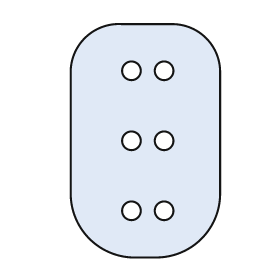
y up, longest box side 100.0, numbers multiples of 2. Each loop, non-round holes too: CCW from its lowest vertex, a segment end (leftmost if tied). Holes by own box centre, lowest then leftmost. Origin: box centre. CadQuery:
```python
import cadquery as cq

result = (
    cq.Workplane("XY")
    .moveTo(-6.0, -50.0)
    .lineTo(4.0, -50.0)
    .threePointArc((24.0, -42.0), (32.0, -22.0))
    .lineTo(32.0, 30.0)
    .threePointArc((26.0, 44.0), (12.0, 50.0))
    .lineTo(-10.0, 50.0)
    .threePointArc((-26.0, 44.0), (-32.0, 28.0))
    .lineTo(-32.0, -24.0)
    .threePointArc((-24.0, -42.0), (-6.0, -50.0))
    .close()
    .moveTo(-6.0, -30.0)
    .circle(4.0)
    .moveTo(8.0, -30.0)
    .circle(4.0)
    .moveTo(-6.0, 0.0)
    .circle(4.0)
    .moveTo(8.0, 0.0)
    .circle(4.0)
    .moveTo(-6.0, 30.0)
    .circle(4.0)
    .moveTo(8.0, 30.0)
    .circle(4.0)
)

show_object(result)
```